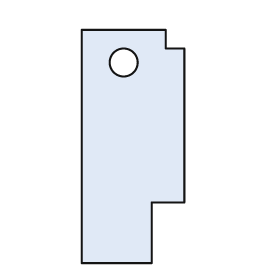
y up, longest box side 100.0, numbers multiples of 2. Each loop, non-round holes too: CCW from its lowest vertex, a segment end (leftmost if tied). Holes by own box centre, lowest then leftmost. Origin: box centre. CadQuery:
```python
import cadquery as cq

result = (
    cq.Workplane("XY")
    .moveTo(-22.0, -50.0)
    .lineTo(8.0, -50.0)
    .lineTo(8.0, -24.0)
    .lineTo(22.0, -24.0)
    .lineTo(22.0, 42.0)
    .lineTo(14.0, 42.0)
    .lineTo(14.0, 50.0)
    .lineTo(-22.0, 50.0)
    .close()
    .moveTo(-4.0, 36.0)
    .circle(6.0)
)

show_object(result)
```